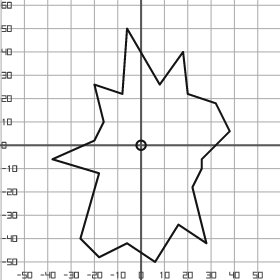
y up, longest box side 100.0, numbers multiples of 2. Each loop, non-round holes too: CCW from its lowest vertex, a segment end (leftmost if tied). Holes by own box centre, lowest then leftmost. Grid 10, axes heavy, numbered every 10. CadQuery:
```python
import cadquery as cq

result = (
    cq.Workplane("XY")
    .moveTo(6.0, -50.0)
    .lineTo(16.0, -34.0)
    .lineTo(28.0, -42.0)
    .lineTo(22.0, -18.0)
    .lineTo(26.0, -10.0)
    .lineTo(26.0, -6.0)
    .lineTo(38.0, 6.0)
    .lineTo(32.0, 18.0)
    .lineTo(20.0, 22.0)
    .lineTo(18.0, 40.0)
    .lineTo(8.0, 26.0)
    .lineTo(-6.0, 50.0)
    .lineTo(-8.0, 22.0)
    .lineTo(-20.0, 26.0)
    .lineTo(-16.0, 10.0)
    .lineTo(-20.0, 2.0)
    .lineTo(-38.0, -6.0)
    .lineTo(-18.0, -12.0)
    .lineTo(-26.0, -40.0)
    .lineTo(-18.0, -48.0)
    .lineTo(-6.0, -42.0)
    .close()
    .moveTo(0.0, 0.0)
    .circle(2.0)
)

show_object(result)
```